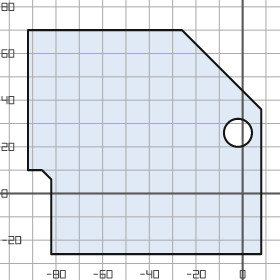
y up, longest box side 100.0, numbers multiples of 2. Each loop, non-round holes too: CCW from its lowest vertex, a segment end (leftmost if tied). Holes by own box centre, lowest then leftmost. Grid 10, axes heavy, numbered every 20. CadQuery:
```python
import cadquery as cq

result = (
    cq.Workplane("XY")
    .moveTo(-82.0, -26.0)
    .lineTo(8.0, -26.0)
    .lineTo(8.0, 36.0)
    .lineTo(-26.0, 70.0)
    .lineTo(-92.0, 70.0)
    .lineTo(-92.0, 10.0)
    .lineTo(-86.0, 10.0)
    .lineTo(-82.0, 6.0)
    .close()
    .moveTo(-2.0, 26.0)
    .circle(6.0)
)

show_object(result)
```